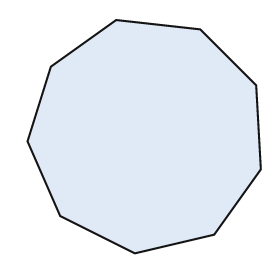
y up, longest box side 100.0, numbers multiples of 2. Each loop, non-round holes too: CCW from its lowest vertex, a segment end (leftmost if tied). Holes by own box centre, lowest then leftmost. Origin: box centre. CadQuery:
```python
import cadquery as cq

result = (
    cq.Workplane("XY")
    .moveTo(-4.0, -50.0)
    .lineTo(30.0, -42.0)
    .lineTo(50.0, -14.0)
    .lineTo(48.0, 22.0)
    .lineTo(24.0, 46.0)
    .lineTo(-12.0, 50.0)
    .lineTo(-40.0, 30.0)
    .lineTo(-50.0, -2.0)
    .lineTo(-36.0, -34.0)
    .close()
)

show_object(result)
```